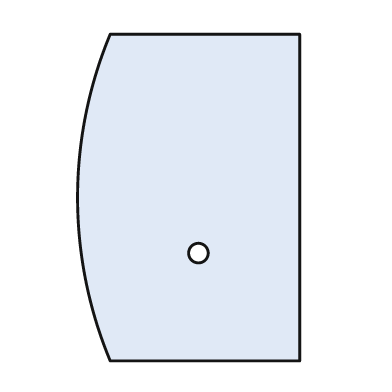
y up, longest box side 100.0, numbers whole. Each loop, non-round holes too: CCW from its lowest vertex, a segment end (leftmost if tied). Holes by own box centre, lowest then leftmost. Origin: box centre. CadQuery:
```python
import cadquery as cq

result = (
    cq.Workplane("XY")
    .moveTo(-24.0, -50.0)
    .lineTo(34.0, -50.0)
    .lineTo(34.0, 50.0)
    .lineTo(-24.0, 50.0)
    .threePointArc((-34.0, 0.0), (-24.0, -50.0))
    .close()
    .moveTo(3.0, -17.0)
    .circle(3.0)
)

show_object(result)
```